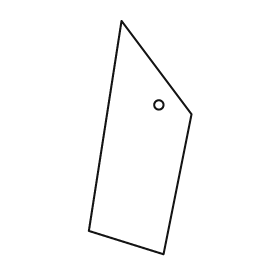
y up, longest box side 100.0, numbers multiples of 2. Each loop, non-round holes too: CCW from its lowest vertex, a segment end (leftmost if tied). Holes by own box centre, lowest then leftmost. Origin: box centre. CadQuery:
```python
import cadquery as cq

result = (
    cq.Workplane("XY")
    .moveTo(10.0, -50.0)
    .lineTo(22.0, 10.0)
    .lineTo(-8.0, 50.0)
    .lineTo(-22.0, -40.0)
    .close()
    .moveTo(8.0, 14.0)
    .circle(2.0)
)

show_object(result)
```